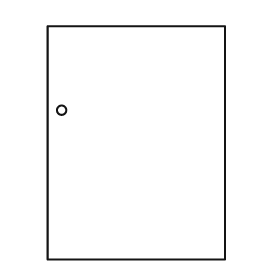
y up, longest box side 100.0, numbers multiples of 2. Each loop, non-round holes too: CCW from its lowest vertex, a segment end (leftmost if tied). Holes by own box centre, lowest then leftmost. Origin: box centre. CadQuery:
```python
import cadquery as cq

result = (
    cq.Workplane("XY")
    .moveTo(-38.0, -50.0)
    .lineTo(38.0, -50.0)
    .lineTo(38.0, 50.0)
    .lineTo(-38.0, 50.0)
    .close()
    .moveTo(-32.0, 14.0)
    .circle(2.0)
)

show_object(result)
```